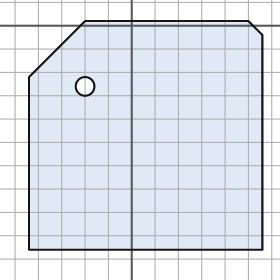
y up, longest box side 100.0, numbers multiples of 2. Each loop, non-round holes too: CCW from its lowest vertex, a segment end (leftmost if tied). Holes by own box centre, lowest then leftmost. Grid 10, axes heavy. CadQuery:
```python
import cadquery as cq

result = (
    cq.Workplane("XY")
    .moveTo(-44.0, -96.0)
    .lineTo(56.0, -96.0)
    .lineTo(56.0, -4.0)
    .lineTo(50.0, 2.0)
    .lineTo(-20.0, 2.0)
    .lineTo(-44.0, -22.0)
    .close()
    .moveTo(-20.0, -26.0)
    .circle(4.0)
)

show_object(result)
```